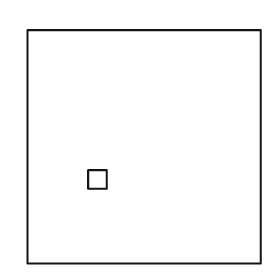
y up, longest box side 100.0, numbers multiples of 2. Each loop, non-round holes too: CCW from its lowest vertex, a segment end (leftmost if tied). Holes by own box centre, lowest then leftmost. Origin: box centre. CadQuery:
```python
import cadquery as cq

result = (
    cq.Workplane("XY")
    .moveTo(-50.0, -50.0)
    .lineTo(50.0, -50.0)
    .lineTo(50.0, 50.0)
    .lineTo(-50.0, 50.0)
    .close()
    .moveTo(-24.0, -18.0)
    .lineTo(-16.0, -18.0)
    .lineTo(-16.0, -10.0)
    .lineTo(-24.0, -10.0)
    .close()
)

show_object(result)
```